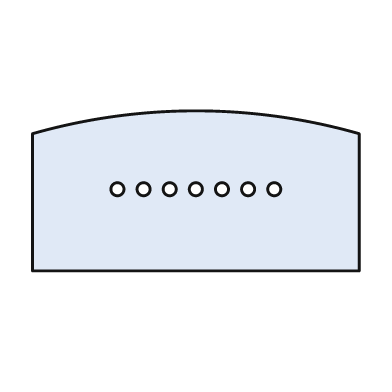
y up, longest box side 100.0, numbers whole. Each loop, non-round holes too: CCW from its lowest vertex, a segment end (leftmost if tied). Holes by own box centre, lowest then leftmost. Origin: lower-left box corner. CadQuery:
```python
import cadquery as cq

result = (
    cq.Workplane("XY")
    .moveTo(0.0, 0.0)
    .lineTo(100.0, 0.0)
    .lineTo(100.0, 42.0)
    .threePointArc((50.0, 49.0), (0.0, 42.0))
    .close()
    .moveTo(26.0, 25.0)
    .circle(2.0)
    .moveTo(34.0, 25.0)
    .circle(2.0)
    .moveTo(42.0, 25.0)
    .circle(2.0)
    .moveTo(50.0, 25.0)
    .circle(2.0)
    .moveTo(58.0, 25.0)
    .circle(2.0)
    .moveTo(66.0, 25.0)
    .circle(2.0)
    .moveTo(74.0, 25.0)
    .circle(2.0)
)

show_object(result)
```